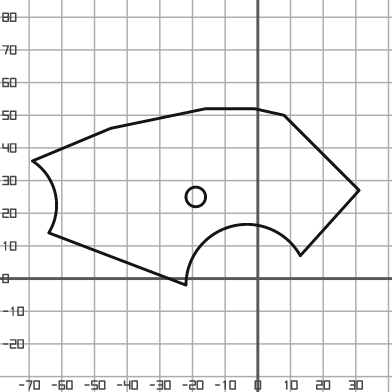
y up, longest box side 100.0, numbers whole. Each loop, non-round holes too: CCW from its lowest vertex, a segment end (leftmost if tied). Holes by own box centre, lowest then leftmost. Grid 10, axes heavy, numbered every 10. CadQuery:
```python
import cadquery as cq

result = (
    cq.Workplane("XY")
    .moveTo(-22.0, -2.0)
    .threePointArc((-8.0, 16.0), (13.0, 7.0))
    .lineTo(31.0, 27.0)
    .lineTo(8.0, 50.0)
    .lineTo(-1.0, 52.0)
    .lineTo(-16.0, 52.0)
    .lineTo(-45.0, 46.0)
    .lineTo(-69.0, 36.0)
    .threePointArc((-62.0, 26.0), (-64.0, 14.0))
    .close()
    .moveTo(-19.0, 25.0)
    .circle(3.0)
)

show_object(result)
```